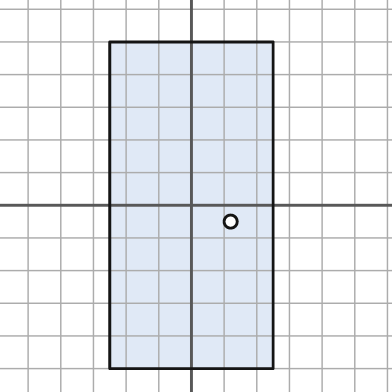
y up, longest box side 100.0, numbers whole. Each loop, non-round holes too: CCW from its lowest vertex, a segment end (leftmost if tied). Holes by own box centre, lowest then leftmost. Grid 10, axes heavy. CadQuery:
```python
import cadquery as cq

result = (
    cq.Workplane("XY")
    .moveTo(-25.0, -50.0)
    .lineTo(25.0, -50.0)
    .lineTo(25.0, 50.0)
    .lineTo(-25.0, 50.0)
    .close()
    .moveTo(12.0, -5.0)
    .circle(2.0)
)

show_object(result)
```